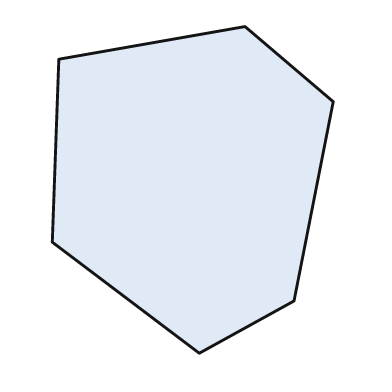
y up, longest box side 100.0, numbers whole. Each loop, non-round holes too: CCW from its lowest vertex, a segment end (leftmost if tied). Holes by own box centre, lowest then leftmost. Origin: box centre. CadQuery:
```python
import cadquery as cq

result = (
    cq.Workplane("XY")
    .moveTo(2.0, -50.0)
    .lineTo(31.0, -34.0)
    .lineTo(43.0, 27.0)
    .lineTo(16.0, 50.0)
    .lineTo(-41.0, 40.0)
    .lineTo(-43.0, -16.0)
    .close()
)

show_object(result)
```